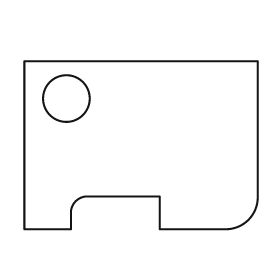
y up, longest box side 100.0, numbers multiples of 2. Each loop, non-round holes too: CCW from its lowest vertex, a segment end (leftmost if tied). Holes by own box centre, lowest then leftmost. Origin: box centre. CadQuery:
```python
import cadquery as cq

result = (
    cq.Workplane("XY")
    .moveTo(-50.0, -36.0)
    .lineTo(-30.0, -36.0)
    .lineTo(-30.0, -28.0)
    .threePointArc((-28.0, -24.0), (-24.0, -22.0))
    .lineTo(8.0, -22.0)
    .lineTo(8.0, -36.0)
    .lineTo(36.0, -36.0)
    .threePointArc((46.0, -32.0), (50.0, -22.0))
    .lineTo(50.0, 36.0)
    .lineTo(-50.0, 36.0)
    .close()
    .moveTo(-32.0, 20.0)
    .circle(10.0)
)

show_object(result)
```